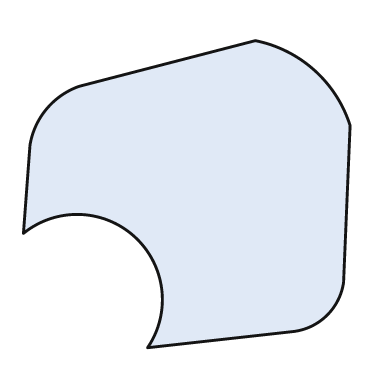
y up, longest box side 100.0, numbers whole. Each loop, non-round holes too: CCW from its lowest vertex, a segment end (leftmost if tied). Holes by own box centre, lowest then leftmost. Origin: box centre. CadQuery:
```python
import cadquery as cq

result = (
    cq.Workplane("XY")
    .moveTo(-12.0, -47.0)
    .lineTo(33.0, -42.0)
    .threePointArc((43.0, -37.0), (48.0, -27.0))
    .lineTo(50.0, 21.0)
    .threePointArc((39.0, 38.0), (21.0, 47.0))
    .lineTo(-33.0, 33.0)
    .threePointArc((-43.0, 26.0), (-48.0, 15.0))
    .lineTo(-50.0, -12.0)
    .threePointArc((-16.0, -13.0), (-12.0, -47.0))
    .close()
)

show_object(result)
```